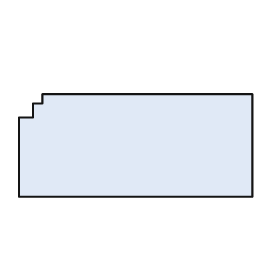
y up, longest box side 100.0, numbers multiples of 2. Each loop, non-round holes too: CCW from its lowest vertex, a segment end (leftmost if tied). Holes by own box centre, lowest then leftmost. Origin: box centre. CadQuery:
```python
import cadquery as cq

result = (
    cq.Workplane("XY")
    .moveTo(-50.0, -22.0)
    .lineTo(50.0, -22.0)
    .lineTo(50.0, 22.0)
    .lineTo(-40.0, 22.0)
    .lineTo(-40.0, 18.0)
    .lineTo(-44.0, 18.0)
    .lineTo(-44.0, 12.0)
    .lineTo(-50.0, 12.0)
    .close()
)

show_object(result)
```